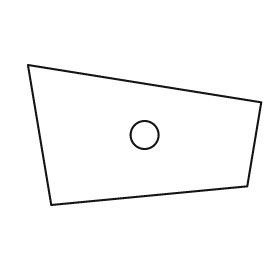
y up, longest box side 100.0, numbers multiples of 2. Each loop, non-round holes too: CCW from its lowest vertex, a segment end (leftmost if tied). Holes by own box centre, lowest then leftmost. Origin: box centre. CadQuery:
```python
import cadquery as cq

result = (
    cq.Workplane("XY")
    .moveTo(-40.0, -30.0)
    .lineTo(44.0, -22.0)
    .lineTo(50.0, 14.0)
    .lineTo(-50.0, 30.0)
    .close()
    .moveTo(0.0, 0.0)
    .circle(6.0)
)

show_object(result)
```